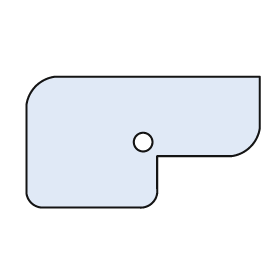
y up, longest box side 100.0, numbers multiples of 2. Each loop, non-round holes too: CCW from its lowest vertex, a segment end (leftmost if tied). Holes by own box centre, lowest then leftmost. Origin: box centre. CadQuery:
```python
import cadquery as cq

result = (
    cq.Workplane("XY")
    .moveTo(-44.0, -28.0)
    .lineTo(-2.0, -28.0)
    .threePointArc((4.0, -26.0), (6.0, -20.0))
    .lineTo(6.0, -6.0)
    .lineTo(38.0, -6.0)
    .threePointArc((46.0, -2.0), (50.0, 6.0))
    .lineTo(50.0, 28.0)
    .lineTo(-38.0, 28.0)
    .threePointArc((-46.0, 24.0), (-50.0, 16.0))
    .lineTo(-50.0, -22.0)
    .threePointArc((-48.0, -26.0), (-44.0, -28.0))
    .close()
    .moveTo(0.0, 0.0)
    .circle(4.0)
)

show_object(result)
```